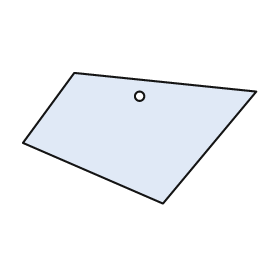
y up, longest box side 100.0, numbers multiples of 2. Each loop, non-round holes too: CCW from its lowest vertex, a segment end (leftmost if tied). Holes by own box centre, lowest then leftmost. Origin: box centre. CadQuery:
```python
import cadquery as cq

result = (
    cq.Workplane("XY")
    .moveTo(10.0, -28.0)
    .lineTo(50.0, 20.0)
    .lineTo(-28.0, 28.0)
    .lineTo(-50.0, -2.0)
    .close()
    .moveTo(0.0, 18.0)
    .circle(2.0)
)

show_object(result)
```